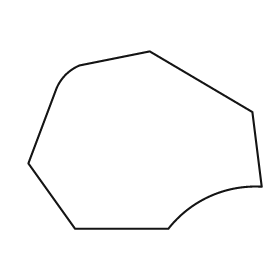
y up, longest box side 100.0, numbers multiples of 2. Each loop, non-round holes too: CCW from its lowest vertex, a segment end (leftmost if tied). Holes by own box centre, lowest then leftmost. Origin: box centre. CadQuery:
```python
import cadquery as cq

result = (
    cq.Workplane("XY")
    .moveTo(-30.0, -38.0)
    .lineTo(10.0, -38.0)
    .threePointArc((28.0, -24.0), (50.0, -20.0))
    .lineTo(46.0, 12.0)
    .lineTo(2.0, 38.0)
    .lineTo(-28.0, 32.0)
    .threePointArc((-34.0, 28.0), (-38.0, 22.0))
    .lineTo(-50.0, -10.0)
    .close()
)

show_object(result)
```